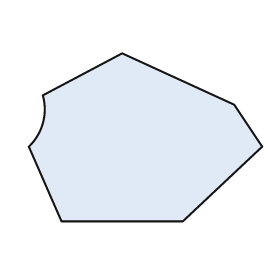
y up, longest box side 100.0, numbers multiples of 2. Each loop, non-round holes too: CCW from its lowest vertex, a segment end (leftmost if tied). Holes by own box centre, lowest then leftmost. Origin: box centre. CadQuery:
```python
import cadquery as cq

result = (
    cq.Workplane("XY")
    .moveTo(-36.0, -36.0)
    .lineTo(16.0, -36.0)
    .lineTo(50.0, -4.0)
    .lineTo(38.0, 14.0)
    .lineTo(-10.0, 36.0)
    .lineTo(-44.0, 18.0)
    .threePointArc((-44.0, 6.0), (-50.0, -4.0))
    .close()
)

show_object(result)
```